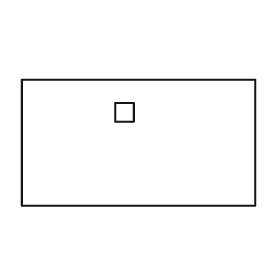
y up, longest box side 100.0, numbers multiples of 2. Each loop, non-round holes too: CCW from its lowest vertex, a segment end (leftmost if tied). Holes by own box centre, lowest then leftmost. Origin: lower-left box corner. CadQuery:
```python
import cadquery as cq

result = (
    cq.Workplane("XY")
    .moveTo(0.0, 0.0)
    .lineTo(100.0, 0.0)
    .lineTo(100.0, 54.0)
    .lineTo(0.0, 54.0)
    .close()
    .moveTo(40.0, 36.0)
    .lineTo(48.0, 36.0)
    .lineTo(48.0, 44.0)
    .lineTo(40.0, 44.0)
    .close()
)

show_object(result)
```